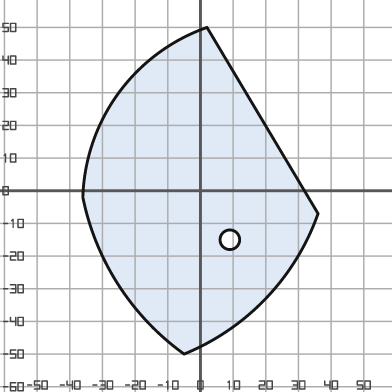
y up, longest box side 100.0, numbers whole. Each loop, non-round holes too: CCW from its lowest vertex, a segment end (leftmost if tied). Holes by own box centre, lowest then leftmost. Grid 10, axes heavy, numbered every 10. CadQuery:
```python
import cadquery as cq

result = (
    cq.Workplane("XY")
    .moveTo(-5.0, -50.0)
    .threePointArc((20.0, -33.0), (36.0, -7.0))
    .lineTo(2.0, 50.0)
    .threePointArc((-25.0, 30.0), (-36.0, -2.0))
    .threePointArc((-25.0, -29.0), (-5.0, -50.0))
    .close()
    .moveTo(9.0, -15.0)
    .circle(3.0)
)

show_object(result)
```